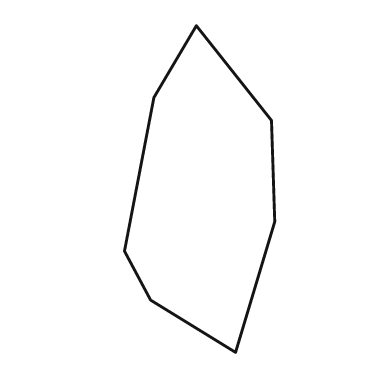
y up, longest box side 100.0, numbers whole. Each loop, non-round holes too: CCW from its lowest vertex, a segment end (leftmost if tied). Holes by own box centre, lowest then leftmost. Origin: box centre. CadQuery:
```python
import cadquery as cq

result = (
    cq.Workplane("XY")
    .moveTo(11.0, -50.0)
    .lineTo(23.0, -10.0)
    .lineTo(22.0, 21.0)
    .lineTo(-1.0, 50.0)
    .lineTo(-14.0, 28.0)
    .lineTo(-23.0, -19.0)
    .lineTo(-15.0, -34.0)
    .close()
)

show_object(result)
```